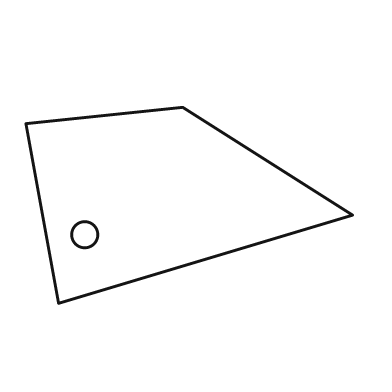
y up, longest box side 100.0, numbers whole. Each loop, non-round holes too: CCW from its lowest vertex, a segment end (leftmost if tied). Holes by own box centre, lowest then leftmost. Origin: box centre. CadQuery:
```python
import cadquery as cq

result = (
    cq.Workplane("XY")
    .moveTo(-40.0, -30.0)
    .lineTo(50.0, -3.0)
    .lineTo(-2.0, 30.0)
    .lineTo(-50.0, 25.0)
    .close()
    .moveTo(-32.0, -9.0)
    .circle(4.0)
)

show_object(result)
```